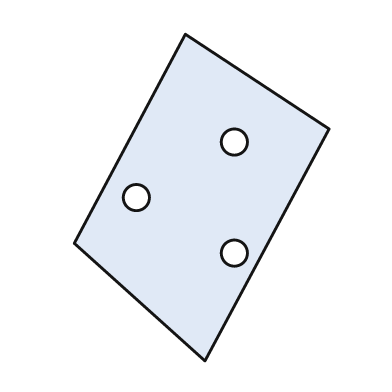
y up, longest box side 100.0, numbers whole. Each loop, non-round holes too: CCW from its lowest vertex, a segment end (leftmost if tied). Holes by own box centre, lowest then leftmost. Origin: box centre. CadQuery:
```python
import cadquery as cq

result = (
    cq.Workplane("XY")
    .moveTo(1.0, -50.0)
    .lineTo(39.0, 21.0)
    .lineTo(-5.0, 50.0)
    .lineTo(-39.0, -14.0)
    .close()
    .moveTo(10.0, -17.0)
    .circle(4.0)
    .moveTo(-20.0, 0.0)
    .circle(4.0)
    .moveTo(10.0, 17.0)
    .circle(4.0)
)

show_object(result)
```